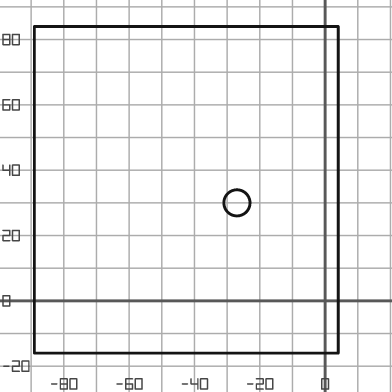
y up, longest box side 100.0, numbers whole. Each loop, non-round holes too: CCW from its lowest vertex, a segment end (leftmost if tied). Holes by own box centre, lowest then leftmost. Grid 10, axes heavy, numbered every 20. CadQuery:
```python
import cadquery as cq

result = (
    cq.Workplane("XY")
    .moveTo(-89.0, -16.0)
    .lineTo(4.0, -16.0)
    .lineTo(4.0, 84.0)
    .lineTo(-89.0, 84.0)
    .close()
    .moveTo(-27.0, 30.0)
    .circle(4.0)
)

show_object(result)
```